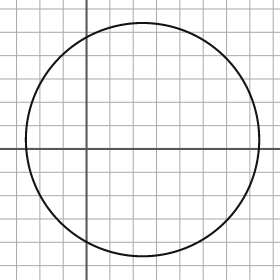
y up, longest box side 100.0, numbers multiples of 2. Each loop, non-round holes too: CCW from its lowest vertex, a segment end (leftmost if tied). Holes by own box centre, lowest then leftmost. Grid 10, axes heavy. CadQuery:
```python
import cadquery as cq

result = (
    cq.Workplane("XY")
    .moveTo(24.0, 4.0)
    .circle(50.0)
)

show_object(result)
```